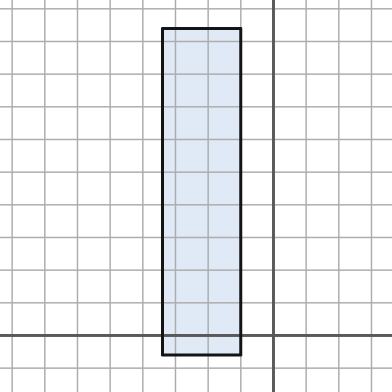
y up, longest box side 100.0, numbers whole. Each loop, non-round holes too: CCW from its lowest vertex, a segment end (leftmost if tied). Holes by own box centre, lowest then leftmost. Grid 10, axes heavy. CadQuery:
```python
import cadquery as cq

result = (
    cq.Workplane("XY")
    .moveTo(-34.0, -6.0)
    .lineTo(-10.0, -6.0)
    .lineTo(-10.0, 94.0)
    .lineTo(-34.0, 94.0)
    .close()
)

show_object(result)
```